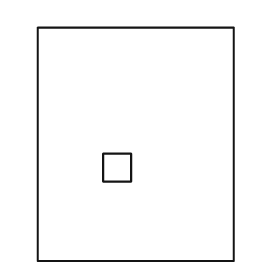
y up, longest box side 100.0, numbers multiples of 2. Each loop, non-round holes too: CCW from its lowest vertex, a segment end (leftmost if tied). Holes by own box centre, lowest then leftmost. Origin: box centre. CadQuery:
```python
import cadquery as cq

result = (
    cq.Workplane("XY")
    .moveTo(-42.0, -50.0)
    .lineTo(42.0, -50.0)
    .lineTo(42.0, 50.0)
    .lineTo(-42.0, 50.0)
    .close()
    .moveTo(-14.0, -16.0)
    .lineTo(-2.0, -16.0)
    .lineTo(-2.0, -4.0)
    .lineTo(-14.0, -4.0)
    .close()
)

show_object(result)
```